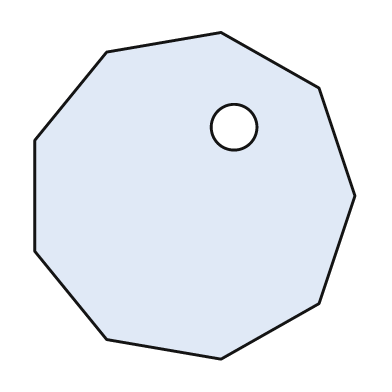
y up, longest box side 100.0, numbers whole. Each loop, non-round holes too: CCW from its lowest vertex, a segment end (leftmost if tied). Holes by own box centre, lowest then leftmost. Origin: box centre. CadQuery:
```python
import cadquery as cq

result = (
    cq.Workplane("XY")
    .moveTo(8.0, -50.0)
    .lineTo(38.0, -33.0)
    .lineTo(49.0, 0.0)
    .lineTo(38.0, 33.0)
    .lineTo(8.0, 50.0)
    .lineTo(-27.0, 44.0)
    .lineTo(-49.0, 17.0)
    .lineTo(-49.0, -17.0)
    .lineTo(-27.0, -44.0)
    .close()
    .moveTo(12.0, 21.0)
    .circle(7.0)
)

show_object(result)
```